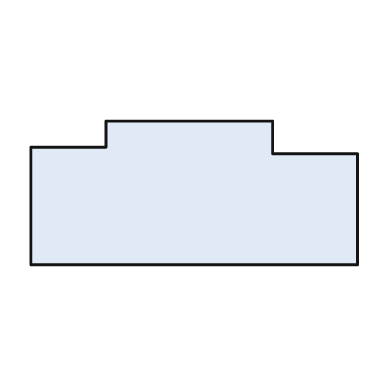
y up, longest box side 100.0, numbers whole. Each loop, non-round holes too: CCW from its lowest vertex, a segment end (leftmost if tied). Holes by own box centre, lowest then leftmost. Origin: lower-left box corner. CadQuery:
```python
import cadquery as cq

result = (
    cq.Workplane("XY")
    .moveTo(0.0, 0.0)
    .lineTo(100.0, 0.0)
    .lineTo(100.0, 34.0)
    .lineTo(74.0, 34.0)
    .lineTo(74.0, 44.0)
    .lineTo(23.0, 44.0)
    .lineTo(23.0, 36.0)
    .lineTo(0.0, 36.0)
    .close()
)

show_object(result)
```